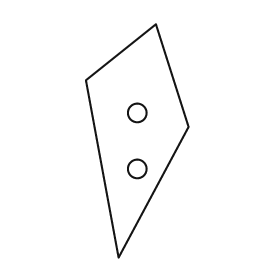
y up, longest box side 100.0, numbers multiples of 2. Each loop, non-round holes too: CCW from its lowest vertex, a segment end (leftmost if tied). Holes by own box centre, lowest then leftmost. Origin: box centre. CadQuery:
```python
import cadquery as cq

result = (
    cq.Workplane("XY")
    .moveTo(-8.0, -50.0)
    .lineTo(22.0, 6.0)
    .lineTo(8.0, 50.0)
    .lineTo(-22.0, 26.0)
    .close()
    .moveTo(0.0, -12.0)
    .circle(4.0)
    .moveTo(0.0, 12.0)
    .circle(4.0)
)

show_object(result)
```